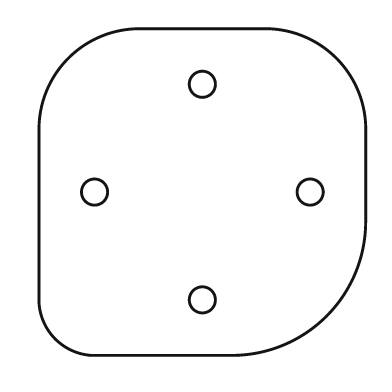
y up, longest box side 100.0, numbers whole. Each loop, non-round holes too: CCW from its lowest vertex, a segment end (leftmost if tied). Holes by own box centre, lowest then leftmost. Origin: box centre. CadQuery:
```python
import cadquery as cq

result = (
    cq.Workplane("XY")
    .moveTo(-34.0, -50.0)
    .lineTo(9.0, -50.0)
    .threePointArc((38.0, -38.0), (50.0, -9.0))
    .lineTo(50.0, 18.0)
    .threePointArc((41.0, 41.0), (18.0, 50.0))
    .lineTo(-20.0, 50.0)
    .threePointArc((-41.0, 41.0), (-50.0, 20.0))
    .lineTo(-50.0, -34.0)
    .threePointArc((-45.0, -45.0), (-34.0, -50.0))
    .close()
    .moveTo(0.0, -33.0)
    .circle(4.0)
    .moveTo(-33.0, 0.0)
    .circle(4.0)
    .moveTo(33.0, 0.0)
    .circle(4.0)
    .moveTo(0.0, 33.0)
    .circle(4.0)
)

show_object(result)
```